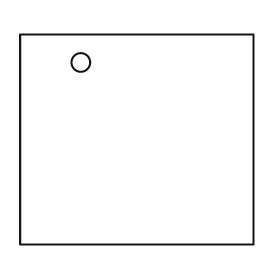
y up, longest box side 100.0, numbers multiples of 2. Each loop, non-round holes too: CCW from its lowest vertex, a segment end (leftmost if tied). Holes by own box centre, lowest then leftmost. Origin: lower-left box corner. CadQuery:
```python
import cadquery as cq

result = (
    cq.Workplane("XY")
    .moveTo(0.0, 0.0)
    .lineTo(100.0, 0.0)
    .lineTo(100.0, 90.0)
    .lineTo(0.0, 90.0)
    .close()
    .moveTo(26.0, 78.0)
    .circle(4.0)
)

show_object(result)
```